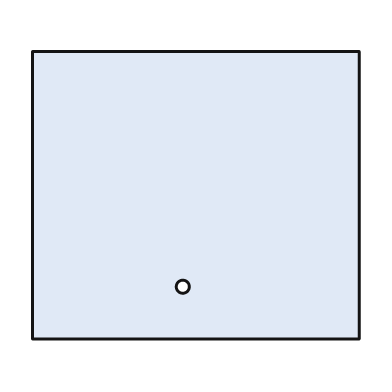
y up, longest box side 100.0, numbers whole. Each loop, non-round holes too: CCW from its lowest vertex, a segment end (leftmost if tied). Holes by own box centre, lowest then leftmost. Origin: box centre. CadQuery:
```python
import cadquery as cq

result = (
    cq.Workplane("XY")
    .moveTo(-50.0, -44.0)
    .lineTo(50.0, -44.0)
    .lineTo(50.0, 44.0)
    .lineTo(-50.0, 44.0)
    .close()
    .moveTo(-4.0, -28.0)
    .circle(2.0)
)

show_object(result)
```